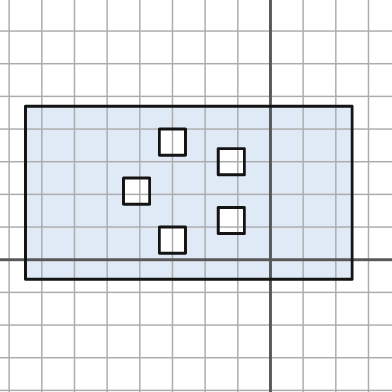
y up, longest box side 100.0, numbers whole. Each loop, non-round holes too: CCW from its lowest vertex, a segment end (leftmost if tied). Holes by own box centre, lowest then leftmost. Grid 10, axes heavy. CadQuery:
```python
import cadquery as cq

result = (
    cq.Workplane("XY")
    .moveTo(-75.0, -6.0)
    .lineTo(25.0, -6.0)
    .lineTo(25.0, 47.0)
    .lineTo(-75.0, 47.0)
    .close()
    .moveTo(-34.0, 2.0)
    .lineTo(-26.0, 2.0)
    .lineTo(-26.0, 10.0)
    .lineTo(-34.0, 10.0)
    .close()
    .moveTo(-16.0, 8.0)
    .lineTo(-8.0, 8.0)
    .lineTo(-8.0, 16.0)
    .lineTo(-16.0, 16.0)
    .close()
    .moveTo(-45.0, 17.0)
    .lineTo(-37.0, 17.0)
    .lineTo(-37.0, 25.0)
    .lineTo(-45.0, 25.0)
    .close()
    .moveTo(-16.0, 26.0)
    .lineTo(-8.0, 26.0)
    .lineTo(-8.0, 34.0)
    .lineTo(-16.0, 34.0)
    .close()
    .moveTo(-34.0, 32.0)
    .lineTo(-26.0, 32.0)
    .lineTo(-26.0, 40.0)
    .lineTo(-34.0, 40.0)
    .close()
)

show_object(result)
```